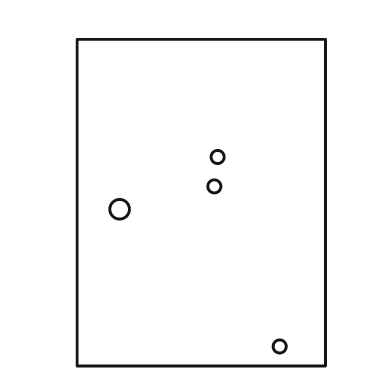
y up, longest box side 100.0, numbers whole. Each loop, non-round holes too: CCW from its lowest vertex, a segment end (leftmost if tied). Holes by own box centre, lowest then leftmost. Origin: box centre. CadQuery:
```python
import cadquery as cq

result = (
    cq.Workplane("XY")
    .moveTo(-38.0, -50.0)
    .lineTo(38.0, -50.0)
    .lineTo(38.0, 50.0)
    .lineTo(-38.0, 50.0)
    .close()
    .moveTo(24.0, -44.0)
    .circle(2.0)
    .moveTo(-25.0, -2.0)
    .circle(3.0)
    .moveTo(4.0, 5.0)
    .circle(2.0)
    .moveTo(5.0, 14.0)
    .circle(2.0)
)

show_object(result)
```